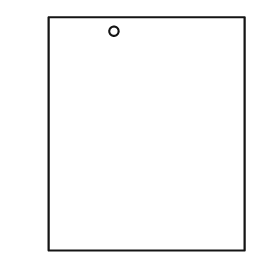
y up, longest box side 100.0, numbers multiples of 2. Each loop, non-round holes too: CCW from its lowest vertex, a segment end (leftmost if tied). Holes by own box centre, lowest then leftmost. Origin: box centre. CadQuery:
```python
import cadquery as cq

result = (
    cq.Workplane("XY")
    .moveTo(-42.0, -50.0)
    .lineTo(42.0, -50.0)
    .lineTo(42.0, 50.0)
    .lineTo(-42.0, 50.0)
    .close()
    .moveTo(-14.0, 44.0)
    .circle(2.0)
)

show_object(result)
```